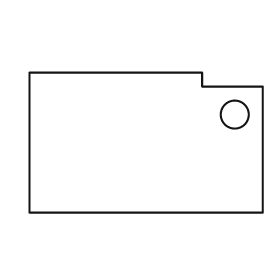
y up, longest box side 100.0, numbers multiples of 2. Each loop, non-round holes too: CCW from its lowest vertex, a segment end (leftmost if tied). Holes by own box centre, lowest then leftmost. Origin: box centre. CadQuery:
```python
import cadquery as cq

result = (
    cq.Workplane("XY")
    .moveTo(-50.0, -30.0)
    .lineTo(50.0, -30.0)
    .lineTo(50.0, 24.0)
    .lineTo(24.0, 24.0)
    .lineTo(24.0, 30.0)
    .lineTo(-50.0, 30.0)
    .close()
    .moveTo(38.0, 12.0)
    .circle(6.0)
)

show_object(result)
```